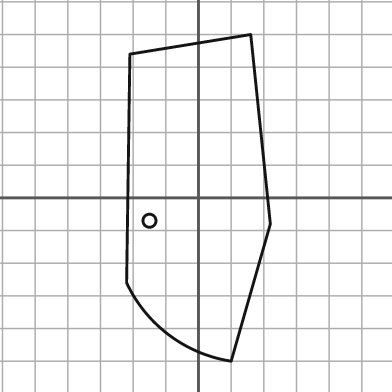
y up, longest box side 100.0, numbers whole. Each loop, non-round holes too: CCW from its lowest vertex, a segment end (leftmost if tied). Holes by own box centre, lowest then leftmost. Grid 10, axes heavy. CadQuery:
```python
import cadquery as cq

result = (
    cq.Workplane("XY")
    .moveTo(10.0, -50.0)
    .lineTo(22.0, -8.0)
    .lineTo(16.0, 50.0)
    .lineTo(-21.0, 44.0)
    .lineTo(-22.0, -26.0)
    .threePointArc((-9.0, -42.0), (10.0, -50.0))
    .close()
    .moveTo(-15.0, -7.0)
    .circle(2.0)
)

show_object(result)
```